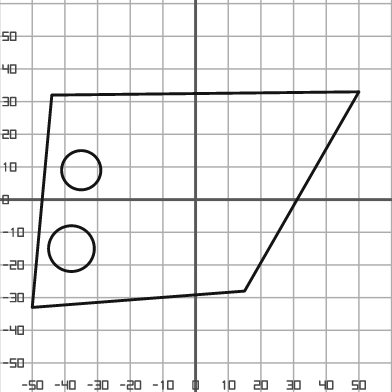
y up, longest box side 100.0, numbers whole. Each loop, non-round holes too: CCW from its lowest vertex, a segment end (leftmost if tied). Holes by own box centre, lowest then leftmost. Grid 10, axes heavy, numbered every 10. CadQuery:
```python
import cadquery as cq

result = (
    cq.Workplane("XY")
    .moveTo(-50.0, -33.0)
    .lineTo(15.0, -28.0)
    .lineTo(50.0, 33.0)
    .lineTo(-44.0, 32.0)
    .close()
    .moveTo(-38.0, -15.0)
    .circle(7.0)
    .moveTo(-35.0, 9.0)
    .circle(6.0)
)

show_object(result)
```